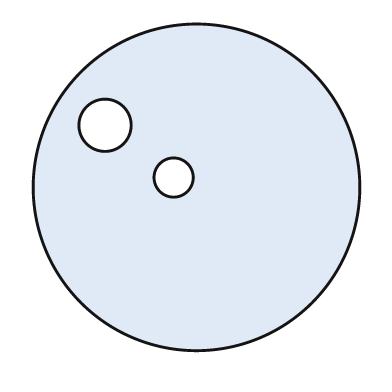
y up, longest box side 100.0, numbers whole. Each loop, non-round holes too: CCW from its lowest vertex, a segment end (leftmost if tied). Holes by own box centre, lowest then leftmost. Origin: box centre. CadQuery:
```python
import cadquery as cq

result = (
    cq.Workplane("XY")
    .moveTo(0.0, 0.0)
    .circle(50.0)
    .moveTo(-7.0, 3.0)
    .circle(6.0)
    .moveTo(-28.0, 19.0)
    .circle(8.0)
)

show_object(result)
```